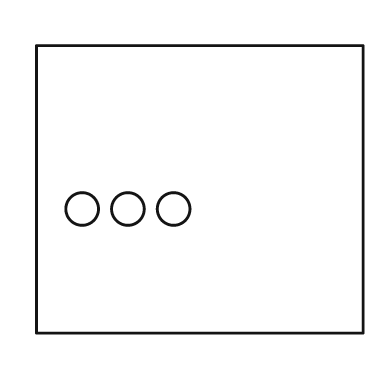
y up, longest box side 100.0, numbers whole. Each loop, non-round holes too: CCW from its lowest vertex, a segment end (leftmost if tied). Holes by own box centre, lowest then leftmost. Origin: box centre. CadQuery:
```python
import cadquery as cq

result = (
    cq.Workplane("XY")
    .moveTo(-50.0, -44.0)
    .lineTo(50.0, -44.0)
    .lineTo(50.0, 44.0)
    .lineTo(-50.0, 44.0)
    .close()
    .moveTo(-36.0, -6.0)
    .circle(5.0)
    .moveTo(-22.0, -6.0)
    .circle(5.0)
    .moveTo(-8.0, -6.0)
    .circle(5.0)
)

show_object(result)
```